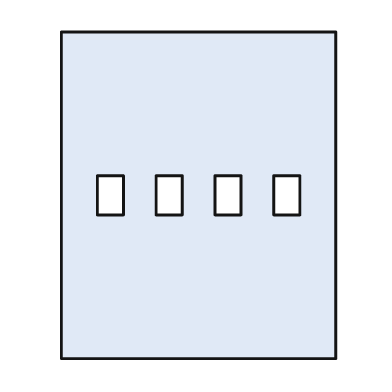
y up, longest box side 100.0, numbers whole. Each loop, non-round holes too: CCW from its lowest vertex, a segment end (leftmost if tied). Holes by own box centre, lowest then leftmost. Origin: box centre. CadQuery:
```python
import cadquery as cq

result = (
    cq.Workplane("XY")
    .moveTo(-42.0, -50.0)
    .lineTo(42.0, -50.0)
    .lineTo(42.0, 50.0)
    .lineTo(-42.0, 50.0)
    .close()
    .moveTo(-31.0, -6.0)
    .lineTo(-23.0, -6.0)
    .lineTo(-23.0, 6.0)
    .lineTo(-31.0, 6.0)
    .close()
    .moveTo(-13.0, -6.0)
    .lineTo(-5.0, -6.0)
    .lineTo(-5.0, 6.0)
    .lineTo(-13.0, 6.0)
    .close()
    .moveTo(5.0, -6.0)
    .lineTo(13.0, -6.0)
    .lineTo(13.0, 6.0)
    .lineTo(5.0, 6.0)
    .close()
    .moveTo(23.0, -6.0)
    .lineTo(31.0, -6.0)
    .lineTo(31.0, 6.0)
    .lineTo(23.0, 6.0)
    .close()
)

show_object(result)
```